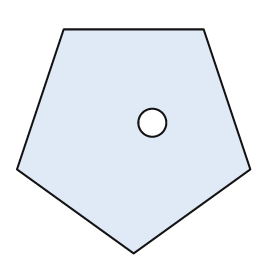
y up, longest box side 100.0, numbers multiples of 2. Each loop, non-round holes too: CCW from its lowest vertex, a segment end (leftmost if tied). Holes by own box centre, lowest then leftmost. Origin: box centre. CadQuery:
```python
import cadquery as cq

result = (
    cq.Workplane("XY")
    .moveTo(0.0, -48.0)
    .lineTo(50.0, -12.0)
    .lineTo(30.0, 48.0)
    .lineTo(-30.0, 48.0)
    .lineTo(-50.0, -12.0)
    .close()
    .moveTo(8.0, 8.0)
    .circle(6.0)
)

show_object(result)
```